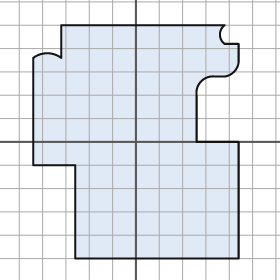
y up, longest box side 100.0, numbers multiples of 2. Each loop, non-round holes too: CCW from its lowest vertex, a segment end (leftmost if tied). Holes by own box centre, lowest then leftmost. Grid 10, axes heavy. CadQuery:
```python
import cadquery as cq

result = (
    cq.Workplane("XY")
    .moveTo(-26.0, -50.0)
    .lineTo(44.0, -50.0)
    .lineTo(44.0, 0.0)
    .lineTo(26.0, 0.0)
    .lineTo(26.0, 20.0)
    .threePointArc((28.0, 26.0), (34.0, 28.0))
    .lineTo(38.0, 28.0)
    .threePointArc((42.0, 30.0), (44.0, 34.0))
    .lineTo(44.0, 42.0)
    .lineTo(38.0, 42.0)
    .threePointArc((36.0, 46.0), (38.0, 50.0))
    .lineTo(-32.0, 50.0)
    .lineTo(-32.0, 36.0)
    .threePointArc((-38.0, 38.0), (-44.0, 36.0))
    .lineTo(-44.0, -10.0)
    .lineTo(-26.0, -10.0)
    .close()
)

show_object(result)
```